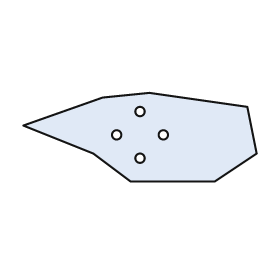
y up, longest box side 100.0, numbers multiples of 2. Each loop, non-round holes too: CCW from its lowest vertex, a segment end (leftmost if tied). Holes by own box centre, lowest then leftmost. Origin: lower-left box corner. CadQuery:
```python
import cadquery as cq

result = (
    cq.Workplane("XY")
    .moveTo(46.0, 0.0)
    .lineTo(82.0, 0.0)
    .lineTo(100.0, 12.0)
    .lineTo(96.0, 32.0)
    .lineTo(54.0, 38.0)
    .lineTo(34.0, 36.0)
    .lineTo(0.0, 24.0)
    .lineTo(30.0, 12.0)
    .close()
    .moveTo(50.0, 10.0)
    .circle(2.0)
    .moveTo(40.0, 20.0)
    .circle(2.0)
    .moveTo(60.0, 20.0)
    .circle(2.0)
    .moveTo(50.0, 30.0)
    .circle(2.0)
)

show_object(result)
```